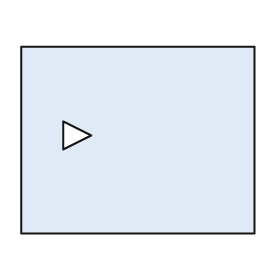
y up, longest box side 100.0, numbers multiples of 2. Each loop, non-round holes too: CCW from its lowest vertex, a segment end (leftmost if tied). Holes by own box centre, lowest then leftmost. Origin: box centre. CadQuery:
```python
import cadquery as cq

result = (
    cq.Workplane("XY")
    .moveTo(-50.0, -40.0)
    .lineTo(50.0, -40.0)
    .lineTo(50.0, 40.0)
    .lineTo(-50.0, 40.0)
    .close()
    .moveTo(-32.0, -4.0)
    .lineTo(-20.0, 2.0)
    .lineTo(-32.0, 8.0)
    .close()
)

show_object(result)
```